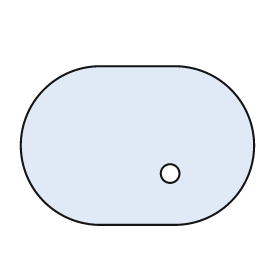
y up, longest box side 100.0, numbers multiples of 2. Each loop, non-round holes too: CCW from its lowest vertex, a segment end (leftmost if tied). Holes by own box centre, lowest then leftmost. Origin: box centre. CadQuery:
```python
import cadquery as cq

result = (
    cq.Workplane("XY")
    .moveTo(-16.0, -34.0)
    .lineTo(16.0, -34.0)
    .threePointArc((50.0, 0.0), (16.0, 34.0))
    .lineTo(-16.0, 34.0)
    .threePointArc((-50.0, 0.0), (-16.0, -34.0))
    .close()
    .moveTo(14.0, -12.0)
    .circle(4.0)
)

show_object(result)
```